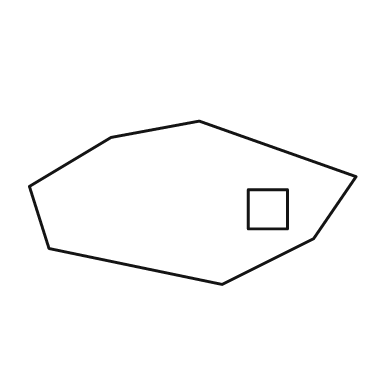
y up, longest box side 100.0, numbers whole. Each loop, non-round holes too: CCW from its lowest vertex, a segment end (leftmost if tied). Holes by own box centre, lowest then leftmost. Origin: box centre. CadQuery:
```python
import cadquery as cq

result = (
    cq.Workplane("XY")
    .moveTo(9.0, -25.0)
    .lineTo(37.0, -11.0)
    .lineTo(50.0, 8.0)
    .lineTo(2.0, 25.0)
    .lineTo(-25.0, 20.0)
    .lineTo(-50.0, 5.0)
    .lineTo(-44.0, -14.0)
    .close()
    .moveTo(17.0, -8.0)
    .lineTo(29.0, -8.0)
    .lineTo(29.0, 4.0)
    .lineTo(17.0, 4.0)
    .close()
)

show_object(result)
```